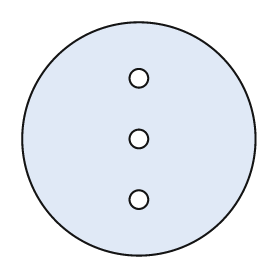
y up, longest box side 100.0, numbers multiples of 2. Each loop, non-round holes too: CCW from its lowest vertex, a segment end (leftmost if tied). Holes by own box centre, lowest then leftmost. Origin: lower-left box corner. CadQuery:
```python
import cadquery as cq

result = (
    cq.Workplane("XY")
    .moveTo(50.0, 50.0)
    .circle(50.0)
    .moveTo(50.0, 24.0)
    .circle(4.0)
    .moveTo(50.0, 50.0)
    .circle(4.0)
    .moveTo(50.0, 76.0)
    .circle(4.0)
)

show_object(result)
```